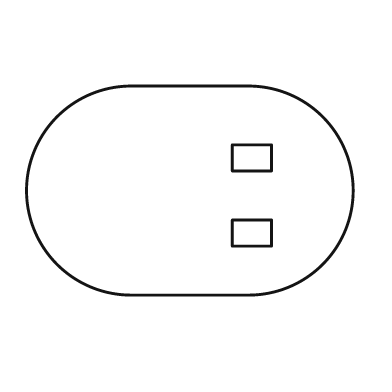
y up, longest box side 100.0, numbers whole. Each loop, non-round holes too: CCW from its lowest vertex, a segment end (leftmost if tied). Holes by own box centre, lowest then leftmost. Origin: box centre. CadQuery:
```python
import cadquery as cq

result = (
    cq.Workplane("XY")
    .moveTo(-18.0, -32.0)
    .lineTo(18.0, -32.0)
    .threePointArc((50.0, 0.0), (18.0, 32.0))
    .lineTo(-18.0, 32.0)
    .threePointArc((-50.0, 0.0), (-18.0, -32.0))
    .close()
    .moveTo(13.0, -17.0)
    .lineTo(25.0, -17.0)
    .lineTo(25.0, -9.0)
    .lineTo(13.0, -9.0)
    .close()
    .moveTo(13.0, 6.0)
    .lineTo(25.0, 6.0)
    .lineTo(25.0, 14.0)
    .lineTo(13.0, 14.0)
    .close()
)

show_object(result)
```